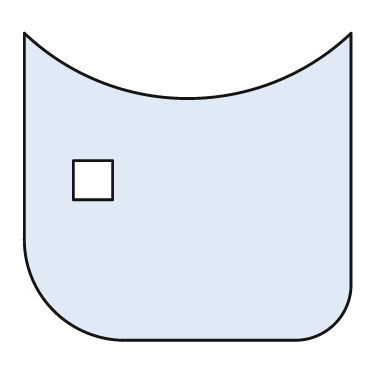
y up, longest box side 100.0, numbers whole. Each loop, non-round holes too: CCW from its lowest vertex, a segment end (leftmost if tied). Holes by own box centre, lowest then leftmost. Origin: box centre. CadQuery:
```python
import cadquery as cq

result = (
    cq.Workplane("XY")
    .moveTo(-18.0, -47.0)
    .lineTo(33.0, -47.0)
    .threePointArc((45.0, -42.0), (50.0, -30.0))
    .lineTo(50.0, 47.0)
    .threePointArc((0.0, 27.0), (-50.0, 47.0))
    .lineTo(-50.0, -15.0)
    .threePointArc((-41.0, -38.0), (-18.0, -47.0))
    .close()
    .moveTo(-35.0, -4.0)
    .lineTo(-23.0, -4.0)
    .lineTo(-23.0, 8.0)
    .lineTo(-35.0, 8.0)
    .close()
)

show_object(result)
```